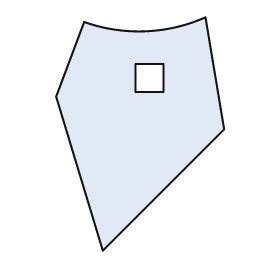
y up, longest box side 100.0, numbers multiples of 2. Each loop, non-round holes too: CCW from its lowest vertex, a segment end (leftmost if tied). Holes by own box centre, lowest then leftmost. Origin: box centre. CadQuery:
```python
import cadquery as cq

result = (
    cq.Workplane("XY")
    .moveTo(-16.0, -50.0)
    .lineTo(36.0, 2.0)
    .lineTo(28.0, 50.0)
    .threePointArc((2.0, 44.0), (-24.0, 48.0))
    .lineTo(-36.0, 16.0)
    .close()
    .moveTo(-2.0, 18.0)
    .lineTo(10.0, 18.0)
    .lineTo(10.0, 30.0)
    .lineTo(-2.0, 30.0)
    .close()
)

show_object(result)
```